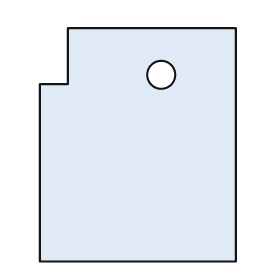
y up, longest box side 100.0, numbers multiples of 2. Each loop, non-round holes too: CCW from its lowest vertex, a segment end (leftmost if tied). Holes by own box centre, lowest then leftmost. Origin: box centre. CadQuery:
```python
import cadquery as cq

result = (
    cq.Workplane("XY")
    .moveTo(-42.0, -50.0)
    .lineTo(42.0, -50.0)
    .lineTo(42.0, 50.0)
    .lineTo(-30.0, 50.0)
    .lineTo(-30.0, 26.0)
    .lineTo(-42.0, 26.0)
    .close()
    .moveTo(10.0, 30.0)
    .circle(6.0)
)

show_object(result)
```